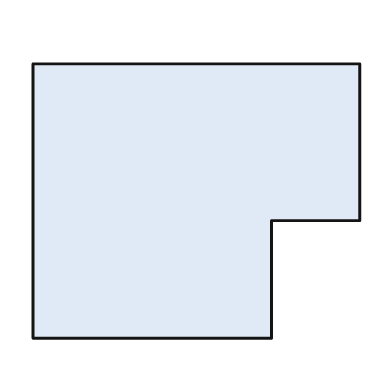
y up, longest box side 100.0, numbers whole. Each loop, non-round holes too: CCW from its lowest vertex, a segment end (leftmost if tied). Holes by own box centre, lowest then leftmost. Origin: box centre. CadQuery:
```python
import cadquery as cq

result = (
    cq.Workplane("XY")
    .moveTo(-50.0, -42.0)
    .lineTo(23.0, -42.0)
    .lineTo(23.0, -6.0)
    .lineTo(50.0, -6.0)
    .lineTo(50.0, 42.0)
    .lineTo(-50.0, 42.0)
    .close()
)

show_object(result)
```